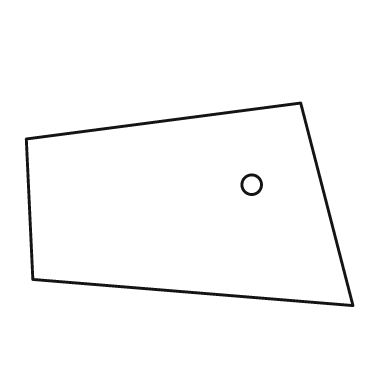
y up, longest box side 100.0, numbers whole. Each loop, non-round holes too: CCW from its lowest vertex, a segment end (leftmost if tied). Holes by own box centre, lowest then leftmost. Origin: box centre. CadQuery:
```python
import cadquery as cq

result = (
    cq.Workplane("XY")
    .moveTo(50.0, -31.0)
    .lineTo(34.0, 31.0)
    .lineTo(-50.0, 20.0)
    .lineTo(-48.0, -23.0)
    .close()
    .moveTo(19.0, 6.0)
    .circle(3.0)
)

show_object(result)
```